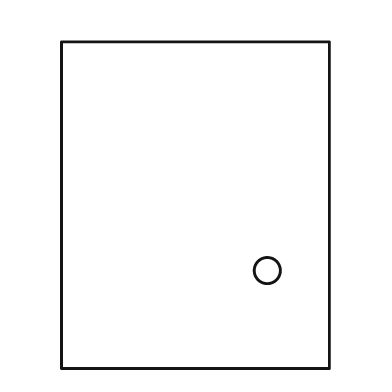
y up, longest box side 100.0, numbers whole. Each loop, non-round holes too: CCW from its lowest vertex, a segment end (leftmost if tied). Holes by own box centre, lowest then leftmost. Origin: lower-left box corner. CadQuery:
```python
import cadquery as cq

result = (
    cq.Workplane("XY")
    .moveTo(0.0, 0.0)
    .lineTo(82.0, 0.0)
    .lineTo(82.0, 100.0)
    .lineTo(0.0, 100.0)
    .close()
    .moveTo(63.0, 30.0)
    .circle(4.0)
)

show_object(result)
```